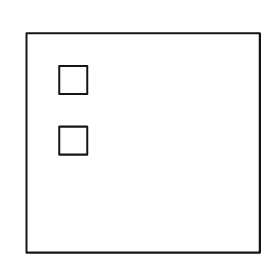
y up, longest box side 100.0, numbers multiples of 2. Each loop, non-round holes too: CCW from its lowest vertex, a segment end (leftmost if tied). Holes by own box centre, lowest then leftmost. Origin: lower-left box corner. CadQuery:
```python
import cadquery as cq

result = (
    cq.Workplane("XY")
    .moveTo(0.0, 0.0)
    .lineTo(100.0, 0.0)
    .lineTo(100.0, 94.0)
    .lineTo(0.0, 94.0)
    .close()
    .moveTo(14.0, 42.0)
    .lineTo(26.0, 42.0)
    .lineTo(26.0, 54.0)
    .lineTo(14.0, 54.0)
    .close()
    .moveTo(14.0, 68.0)
    .lineTo(26.0, 68.0)
    .lineTo(26.0, 80.0)
    .lineTo(14.0, 80.0)
    .close()
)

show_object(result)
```